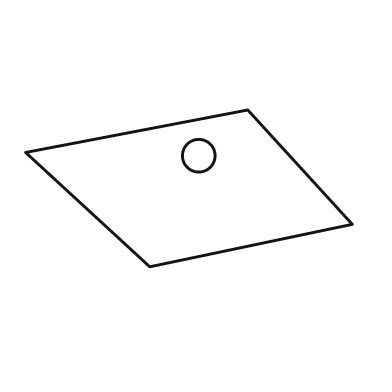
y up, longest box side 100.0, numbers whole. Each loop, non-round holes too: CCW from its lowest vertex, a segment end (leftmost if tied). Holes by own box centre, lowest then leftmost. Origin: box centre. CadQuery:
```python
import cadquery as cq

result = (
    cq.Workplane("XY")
    .moveTo(-12.0, -24.0)
    .lineTo(50.0, -11.0)
    .lineTo(18.0, 24.0)
    .lineTo(-50.0, 11.0)
    .close()
    .moveTo(3.0, 10.0)
    .circle(5.0)
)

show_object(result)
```